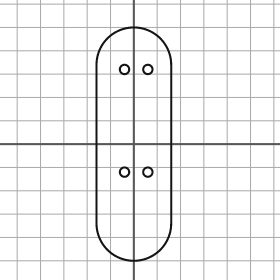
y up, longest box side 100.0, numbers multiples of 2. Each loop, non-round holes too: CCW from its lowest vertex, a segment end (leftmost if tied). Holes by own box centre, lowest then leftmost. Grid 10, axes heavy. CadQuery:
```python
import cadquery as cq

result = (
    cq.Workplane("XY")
    .moveTo(-16.0, -34.0)
    .threePointArc((0.0, -50.0), (16.0, -34.0))
    .lineTo(16.0, 34.0)
    .threePointArc((0.0, 50.0), (-16.0, 34.0))
    .close()
    .moveTo(-4.0, -12.0)
    .circle(2.0)
    .moveTo(6.0, -12.0)
    .circle(2.0)
    .moveTo(-4.0, 32.0)
    .circle(2.0)
    .moveTo(6.0, 32.0)
    .circle(2.0)
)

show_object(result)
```